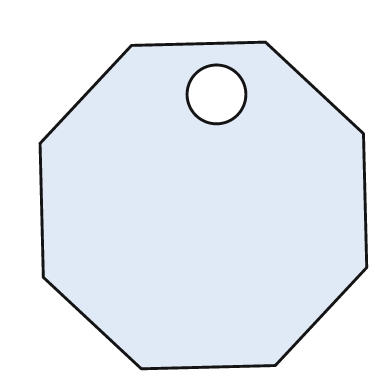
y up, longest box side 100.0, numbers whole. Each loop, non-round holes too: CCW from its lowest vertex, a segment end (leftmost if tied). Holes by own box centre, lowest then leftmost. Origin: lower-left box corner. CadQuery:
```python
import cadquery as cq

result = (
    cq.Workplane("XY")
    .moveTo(31.0, 0.0)
    .lineTo(72.0, 1.0)
    .lineTo(100.0, 31.0)
    .lineTo(99.0, 72.0)
    .lineTo(69.0, 100.0)
    .lineTo(28.0, 99.0)
    .lineTo(0.0, 69.0)
    .lineTo(1.0, 28.0)
    .close()
    .moveTo(54.0, 84.0)
    .circle(9.0)
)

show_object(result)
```